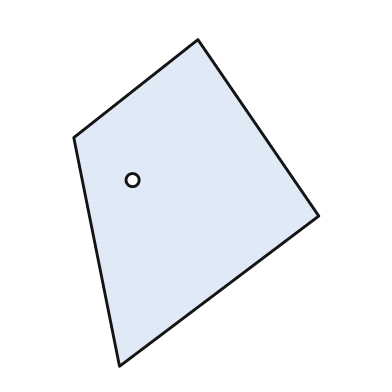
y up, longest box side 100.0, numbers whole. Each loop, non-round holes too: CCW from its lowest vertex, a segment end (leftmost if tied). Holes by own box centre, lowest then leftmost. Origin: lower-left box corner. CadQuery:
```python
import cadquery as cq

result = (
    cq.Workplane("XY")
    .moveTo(14.0, 0.0)
    .lineTo(75.0, 46.0)
    .lineTo(38.0, 100.0)
    .lineTo(0.0, 70.0)
    .close()
    .moveTo(18.0, 57.0)
    .circle(2.0)
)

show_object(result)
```